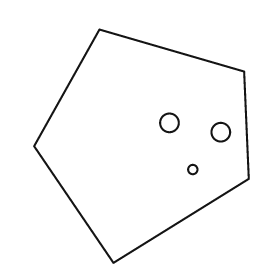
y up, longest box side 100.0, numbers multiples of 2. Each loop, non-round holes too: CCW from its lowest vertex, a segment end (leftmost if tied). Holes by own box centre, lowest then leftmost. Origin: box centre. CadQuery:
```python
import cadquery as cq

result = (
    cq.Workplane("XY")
    .moveTo(-12.0, -50.0)
    .lineTo(46.0, -14.0)
    .lineTo(44.0, 32.0)
    .lineTo(-18.0, 50.0)
    .lineTo(-46.0, 0.0)
    .close()
    .moveTo(22.0, -10.0)
    .circle(2.0)
    .moveTo(34.0, 6.0)
    .circle(4.0)
    .moveTo(12.0, 10.0)
    .circle(4.0)
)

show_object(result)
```